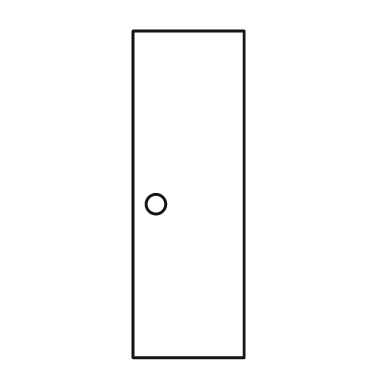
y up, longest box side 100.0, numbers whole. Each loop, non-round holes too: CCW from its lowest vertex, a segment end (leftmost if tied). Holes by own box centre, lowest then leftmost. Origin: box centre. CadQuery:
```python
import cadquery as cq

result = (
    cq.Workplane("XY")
    .moveTo(-17.0, -50.0)
    .lineTo(17.0, -50.0)
    .lineTo(17.0, 50.0)
    .lineTo(-17.0, 50.0)
    .close()
    .moveTo(-10.0, -3.0)
    .circle(3.0)
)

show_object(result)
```